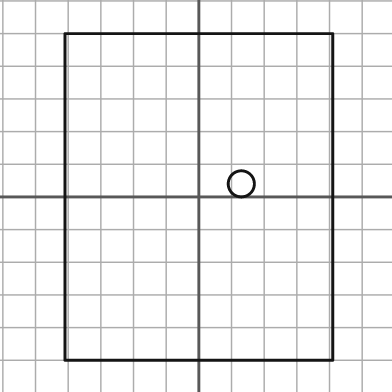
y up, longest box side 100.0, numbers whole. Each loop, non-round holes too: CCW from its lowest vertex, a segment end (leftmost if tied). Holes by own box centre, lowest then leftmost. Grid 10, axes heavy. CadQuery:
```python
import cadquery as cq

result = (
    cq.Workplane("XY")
    .moveTo(-41.0, -50.0)
    .lineTo(41.0, -50.0)
    .lineTo(41.0, 50.0)
    .lineTo(-41.0, 50.0)
    .close()
    .moveTo(13.0, 4.0)
    .circle(4.0)
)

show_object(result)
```